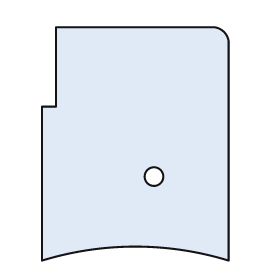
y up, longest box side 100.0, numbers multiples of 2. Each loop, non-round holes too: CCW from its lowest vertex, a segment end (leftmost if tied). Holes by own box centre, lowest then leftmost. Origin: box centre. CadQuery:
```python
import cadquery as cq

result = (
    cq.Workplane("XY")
    .moveTo(-40.0, -50.0)
    .threePointArc((0.0, -44.0), (40.0, -50.0))
    .lineTo(40.0, 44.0)
    .threePointArc((38.0, 48.0), (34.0, 50.0))
    .lineTo(-34.0, 50.0)
    .lineTo(-34.0, 16.0)
    .lineTo(-40.0, 16.0)
    .close()
    .moveTo(8.0, -14.0)
    .circle(4.0)
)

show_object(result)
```